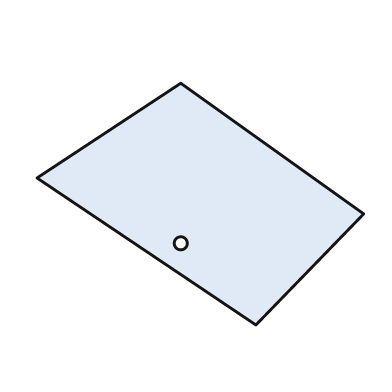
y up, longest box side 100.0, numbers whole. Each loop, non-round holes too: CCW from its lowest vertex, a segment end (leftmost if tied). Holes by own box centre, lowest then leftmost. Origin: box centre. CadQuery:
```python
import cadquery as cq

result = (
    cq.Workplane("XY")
    .moveTo(17.0, -37.0)
    .lineTo(50.0, -3.0)
    .lineTo(-6.0, 37.0)
    .lineTo(-50.0, 8.0)
    .close()
    .moveTo(-6.0, -12.0)
    .circle(2.0)
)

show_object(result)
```